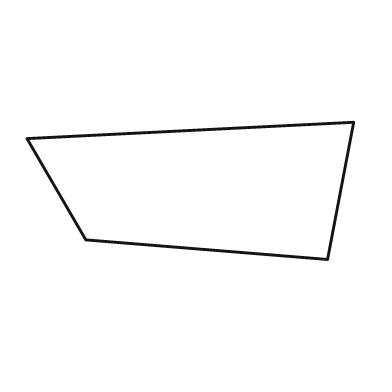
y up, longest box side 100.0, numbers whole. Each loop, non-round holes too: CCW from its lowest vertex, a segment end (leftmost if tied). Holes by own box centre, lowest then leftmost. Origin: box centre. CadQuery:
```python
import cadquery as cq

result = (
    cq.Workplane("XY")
    .moveTo(42.0, -21.0)
    .lineTo(50.0, 21.0)
    .lineTo(-50.0, 16.0)
    .lineTo(-32.0, -15.0)
    .close()
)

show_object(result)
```